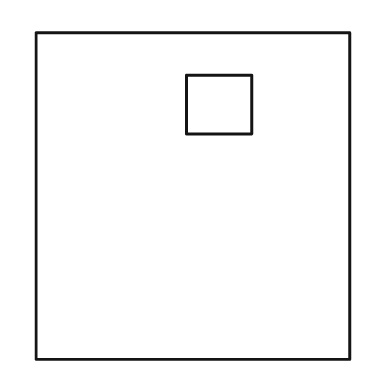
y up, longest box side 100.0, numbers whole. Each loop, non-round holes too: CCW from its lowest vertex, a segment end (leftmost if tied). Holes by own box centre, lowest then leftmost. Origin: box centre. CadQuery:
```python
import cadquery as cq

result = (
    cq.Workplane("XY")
    .moveTo(-48.0, -50.0)
    .lineTo(48.0, -50.0)
    .lineTo(48.0, 50.0)
    .lineTo(-48.0, 50.0)
    .close()
    .moveTo(-2.0, 19.0)
    .lineTo(18.0, 19.0)
    .lineTo(18.0, 37.0)
    .lineTo(-2.0, 37.0)
    .close()
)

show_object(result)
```